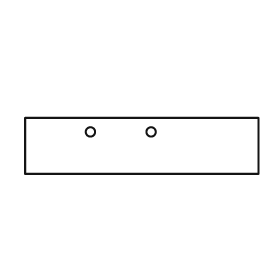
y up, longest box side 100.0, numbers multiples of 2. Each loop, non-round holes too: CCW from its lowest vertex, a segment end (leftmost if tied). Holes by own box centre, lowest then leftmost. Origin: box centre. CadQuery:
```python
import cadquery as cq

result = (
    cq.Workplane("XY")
    .moveTo(-50.0, -12.0)
    .lineTo(50.0, -12.0)
    .lineTo(50.0, 12.0)
    .lineTo(-50.0, 12.0)
    .close()
    .moveTo(-22.0, 6.0)
    .circle(2.0)
    .moveTo(4.0, 6.0)
    .circle(2.0)
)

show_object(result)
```